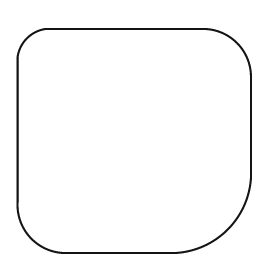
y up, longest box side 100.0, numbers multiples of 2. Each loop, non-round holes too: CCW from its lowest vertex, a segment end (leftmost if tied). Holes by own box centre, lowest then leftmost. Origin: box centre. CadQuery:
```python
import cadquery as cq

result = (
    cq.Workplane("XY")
    .moveTo(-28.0, -48.0)
    .lineTo(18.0, -48.0)
    .threePointArc((40.0, -38.0), (50.0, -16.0))
    .lineTo(50.0, 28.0)
    .threePointArc((44.0, 42.0), (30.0, 48.0))
    .lineTo(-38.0, 48.0)
    .threePointArc((-46.0, 44.0), (-50.0, 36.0))
    .lineTo(-50.0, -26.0)
    .threePointArc((-44.0, -42.0), (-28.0, -48.0))
    .close()
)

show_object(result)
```